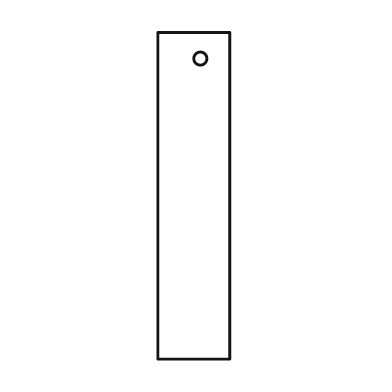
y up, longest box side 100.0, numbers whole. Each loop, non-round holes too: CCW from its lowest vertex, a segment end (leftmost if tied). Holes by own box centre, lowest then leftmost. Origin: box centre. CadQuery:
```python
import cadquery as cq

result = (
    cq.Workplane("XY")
    .moveTo(-11.0, -50.0)
    .lineTo(11.0, -50.0)
    .lineTo(11.0, 50.0)
    .lineTo(-11.0, 50.0)
    .close()
    .moveTo(2.0, 42.0)
    .circle(2.0)
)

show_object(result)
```